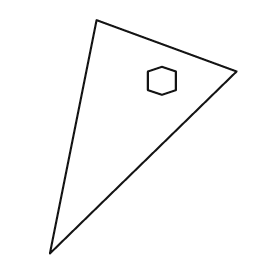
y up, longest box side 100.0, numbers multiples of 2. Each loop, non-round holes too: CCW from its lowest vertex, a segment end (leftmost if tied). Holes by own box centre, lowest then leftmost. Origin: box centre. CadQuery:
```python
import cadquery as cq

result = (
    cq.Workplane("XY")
    .moveTo(-40.0, -50.0)
    .lineTo(40.0, 28.0)
    .lineTo(-20.0, 50.0)
    .close()
    .moveTo(8.0, 18.0)
    .lineTo(14.0, 20.0)
    .lineTo(14.0, 28.0)
    .lineTo(8.0, 30.0)
    .lineTo(2.0, 28.0)
    .lineTo(2.0, 20.0)
    .close()
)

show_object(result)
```